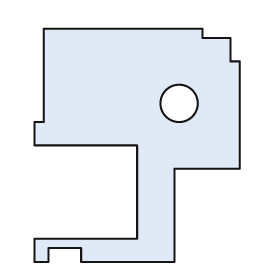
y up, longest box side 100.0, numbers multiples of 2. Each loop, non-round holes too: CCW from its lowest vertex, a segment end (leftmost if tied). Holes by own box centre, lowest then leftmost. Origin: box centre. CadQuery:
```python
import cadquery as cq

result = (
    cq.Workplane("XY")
    .moveTo(-44.0, -50.0)
    .lineTo(-38.0, -50.0)
    .lineTo(-38.0, -44.0)
    .lineTo(-24.0, -44.0)
    .lineTo(-24.0, -50.0)
    .lineTo(16.0, -50.0)
    .lineTo(16.0, -10.0)
    .lineTo(44.0, -10.0)
    .lineTo(44.0, 36.0)
    .lineTo(40.0, 36.0)
    .lineTo(40.0, 46.0)
    .lineTo(28.0, 46.0)
    .lineTo(28.0, 50.0)
    .lineTo(-40.0, 50.0)
    .lineTo(-40.0, 10.0)
    .lineTo(-44.0, 10.0)
    .lineTo(-44.0, 0.0)
    .lineTo(0.0, 0.0)
    .lineTo(0.0, -40.0)
    .lineTo(-44.0, -40.0)
    .close()
    .moveTo(18.0, 18.0)
    .circle(8.0)
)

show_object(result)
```